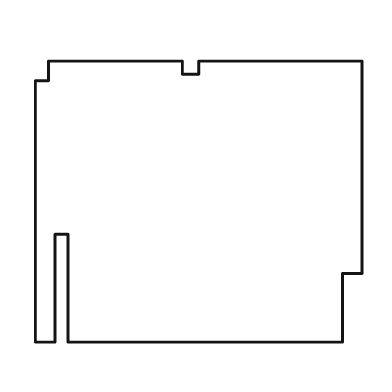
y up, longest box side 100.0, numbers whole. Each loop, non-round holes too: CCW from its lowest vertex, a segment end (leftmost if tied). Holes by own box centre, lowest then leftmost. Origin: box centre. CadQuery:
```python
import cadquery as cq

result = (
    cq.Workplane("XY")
    .moveTo(-50.0, -43.0)
    .lineTo(-44.0, -43.0)
    .lineTo(-44.0, -10.0)
    .lineTo(-40.0, -10.0)
    .lineTo(-40.0, -43.0)
    .lineTo(44.0, -43.0)
    .lineTo(44.0, -22.0)
    .lineTo(50.0, -22.0)
    .lineTo(50.0, 43.0)
    .lineTo(0.0, 43.0)
    .lineTo(0.0, 39.0)
    .lineTo(-5.0, 39.0)
    .lineTo(-5.0, 43.0)
    .lineTo(-46.0, 43.0)
    .lineTo(-46.0, 37.0)
    .lineTo(-50.0, 37.0)
    .close()
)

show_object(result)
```